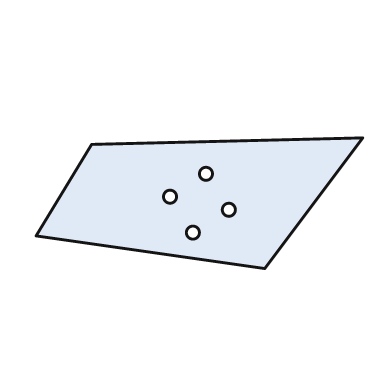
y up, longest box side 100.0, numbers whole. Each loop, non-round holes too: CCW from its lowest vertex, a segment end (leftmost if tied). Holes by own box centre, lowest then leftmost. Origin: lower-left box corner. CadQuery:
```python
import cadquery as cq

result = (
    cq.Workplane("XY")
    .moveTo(70.0, 0.0)
    .lineTo(100.0, 40.0)
    .lineTo(17.0, 38.0)
    .lineTo(0.0, 10.0)
    .close()
    .moveTo(48.0, 11.0)
    .circle(2.0)
    .moveTo(59.0, 18.0)
    .circle(2.0)
    .moveTo(41.0, 22.0)
    .circle(2.0)
    .moveTo(52.0, 29.0)
    .circle(2.0)
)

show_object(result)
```